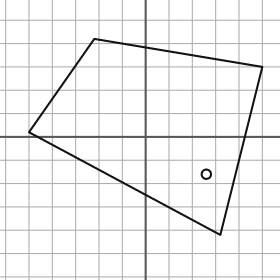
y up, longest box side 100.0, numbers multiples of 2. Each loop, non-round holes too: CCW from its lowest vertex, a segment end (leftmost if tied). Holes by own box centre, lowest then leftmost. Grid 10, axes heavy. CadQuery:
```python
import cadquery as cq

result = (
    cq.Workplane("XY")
    .moveTo(32.0, -42.0)
    .lineTo(50.0, 30.0)
    .lineTo(-22.0, 42.0)
    .lineTo(-50.0, 2.0)
    .close()
    .moveTo(26.0, -16.0)
    .circle(2.0)
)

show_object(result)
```